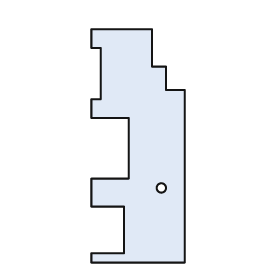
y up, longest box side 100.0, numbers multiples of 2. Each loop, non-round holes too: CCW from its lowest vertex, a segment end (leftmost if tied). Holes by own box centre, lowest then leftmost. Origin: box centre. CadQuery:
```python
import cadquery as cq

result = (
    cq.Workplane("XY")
    .moveTo(-20.0, -50.0)
    .lineTo(20.0, -50.0)
    .lineTo(20.0, 24.0)
    .lineTo(12.0, 24.0)
    .lineTo(12.0, 34.0)
    .lineTo(6.0, 34.0)
    .lineTo(6.0, 50.0)
    .lineTo(-20.0, 50.0)
    .lineTo(-20.0, 42.0)
    .lineTo(-16.0, 42.0)
    .lineTo(-16.0, 20.0)
    .lineTo(-20.0, 20.0)
    .lineTo(-20.0, 12.0)
    .lineTo(-4.0, 12.0)
    .lineTo(-4.0, -14.0)
    .lineTo(-20.0, -14.0)
    .lineTo(-20.0, -26.0)
    .lineTo(-6.0, -26.0)
    .lineTo(-6.0, -46.0)
    .lineTo(-20.0, -46.0)
    .close()
    .moveTo(10.0, -18.0)
    .circle(2.0)
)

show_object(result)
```